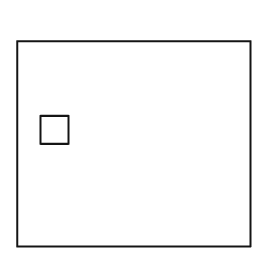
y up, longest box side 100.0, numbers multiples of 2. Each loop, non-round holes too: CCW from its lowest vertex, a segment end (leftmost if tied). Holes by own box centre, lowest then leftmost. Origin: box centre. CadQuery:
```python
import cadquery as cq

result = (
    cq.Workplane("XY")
    .moveTo(-50.0, -44.0)
    .lineTo(50.0, -44.0)
    .lineTo(50.0, 44.0)
    .lineTo(-50.0, 44.0)
    .close()
    .moveTo(-40.0, 0.0)
    .lineTo(-28.0, 0.0)
    .lineTo(-28.0, 12.0)
    .lineTo(-40.0, 12.0)
    .close()
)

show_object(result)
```